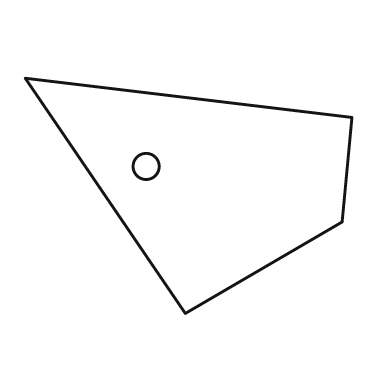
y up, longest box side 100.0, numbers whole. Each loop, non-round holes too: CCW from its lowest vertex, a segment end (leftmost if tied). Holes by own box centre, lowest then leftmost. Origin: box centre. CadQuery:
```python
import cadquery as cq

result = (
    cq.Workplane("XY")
    .moveTo(-1.0, -36.0)
    .lineTo(47.0, -8.0)
    .lineTo(50.0, 24.0)
    .lineTo(-50.0, 36.0)
    .close()
    .moveTo(-13.0, 9.0)
    .circle(4.0)
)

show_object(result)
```